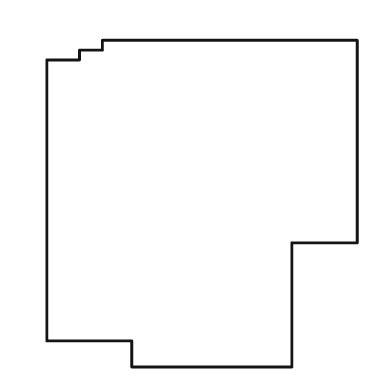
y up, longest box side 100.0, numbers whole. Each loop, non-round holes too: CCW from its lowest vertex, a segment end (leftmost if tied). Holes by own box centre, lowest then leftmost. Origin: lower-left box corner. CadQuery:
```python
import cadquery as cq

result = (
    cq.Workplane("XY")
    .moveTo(26.0, 0.0)
    .lineTo(75.0, 0.0)
    .lineTo(75.0, 38.0)
    .lineTo(95.0, 38.0)
    .lineTo(95.0, 100.0)
    .lineTo(17.0, 100.0)
    .lineTo(17.0, 97.0)
    .lineTo(10.0, 97.0)
    .lineTo(10.0, 94.0)
    .lineTo(0.0, 94.0)
    .lineTo(0.0, 8.0)
    .lineTo(26.0, 8.0)
    .close()
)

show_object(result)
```